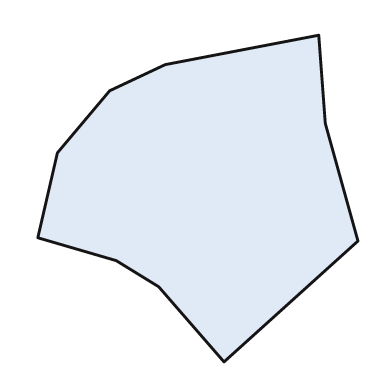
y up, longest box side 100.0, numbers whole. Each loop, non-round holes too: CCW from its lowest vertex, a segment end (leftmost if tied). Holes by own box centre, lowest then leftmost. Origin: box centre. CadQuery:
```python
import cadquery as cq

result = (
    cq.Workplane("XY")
    .moveTo(8.0, -50.0)
    .lineTo(49.0, -13.0)
    .lineTo(39.0, 23.0)
    .lineTo(37.0, 50.0)
    .lineTo(-10.0, 41.0)
    .lineTo(-27.0, 33.0)
    .lineTo(-43.0, 14.0)
    .lineTo(-49.0, -12.0)
    .lineTo(-25.0, -19.0)
    .lineTo(-12.0, -27.0)
    .close()
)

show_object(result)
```